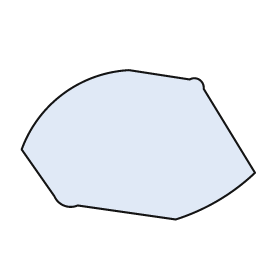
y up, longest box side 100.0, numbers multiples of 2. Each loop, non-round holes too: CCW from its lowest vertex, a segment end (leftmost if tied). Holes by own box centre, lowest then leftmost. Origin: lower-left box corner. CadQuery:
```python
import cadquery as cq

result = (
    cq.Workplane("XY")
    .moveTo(66.0, 0.0)
    .threePointArc((84.0, 8.0), (100.0, 20.0))
    .lineTo(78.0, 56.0)
    .threePointArc((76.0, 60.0), (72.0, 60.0))
    .lineTo(46.0, 64.0)
    .threePointArc((18.0, 54.0), (0.0, 30.0))
    .lineTo(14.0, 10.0)
    .threePointArc((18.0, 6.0), (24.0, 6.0))
    .close()
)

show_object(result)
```